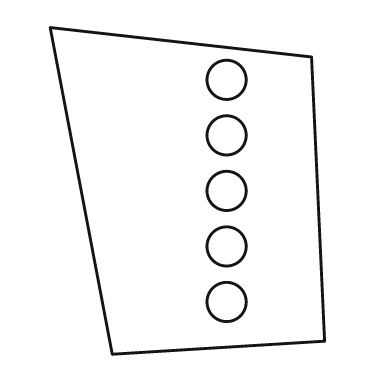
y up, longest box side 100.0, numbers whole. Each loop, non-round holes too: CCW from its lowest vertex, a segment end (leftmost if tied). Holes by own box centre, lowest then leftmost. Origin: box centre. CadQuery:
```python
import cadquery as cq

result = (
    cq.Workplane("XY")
    .moveTo(-23.0, -50.0)
    .lineTo(42.0, -46.0)
    .lineTo(38.0, 41.0)
    .lineTo(-42.0, 50.0)
    .close()
    .moveTo(12.0, -34.0)
    .circle(6.0)
    .moveTo(12.0, -17.0)
    .circle(6.0)
    .moveTo(12.0, 0.0)
    .circle(6.0)
    .moveTo(12.0, 17.0)
    .circle(6.0)
    .moveTo(12.0, 34.0)
    .circle(6.0)
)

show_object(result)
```